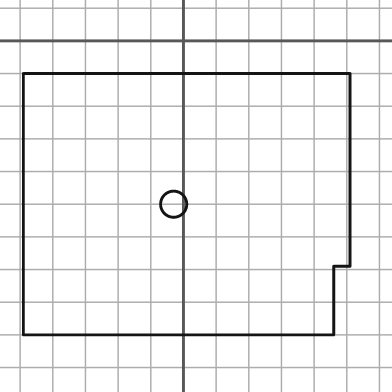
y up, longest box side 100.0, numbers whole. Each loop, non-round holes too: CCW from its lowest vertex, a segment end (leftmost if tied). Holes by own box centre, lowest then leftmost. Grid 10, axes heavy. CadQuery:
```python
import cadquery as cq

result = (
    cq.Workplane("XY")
    .moveTo(-49.0, -90.0)
    .lineTo(46.0, -90.0)
    .lineTo(46.0, -69.0)
    .lineTo(51.0, -69.0)
    .lineTo(51.0, -10.0)
    .lineTo(-49.0, -10.0)
    .close()
    .moveTo(-3.0, -50.0)
    .circle(4.0)
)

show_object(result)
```